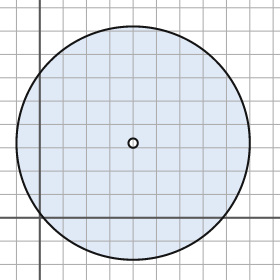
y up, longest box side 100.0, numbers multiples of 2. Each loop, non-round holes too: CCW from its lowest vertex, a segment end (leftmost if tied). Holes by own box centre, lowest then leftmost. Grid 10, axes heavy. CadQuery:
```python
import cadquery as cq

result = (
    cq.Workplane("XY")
    .moveTo(40.0, 32.0)
    .circle(50.0)
    .moveTo(40.0, 32.0)
    .circle(2.0)
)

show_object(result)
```